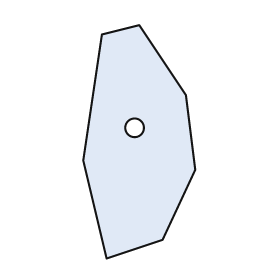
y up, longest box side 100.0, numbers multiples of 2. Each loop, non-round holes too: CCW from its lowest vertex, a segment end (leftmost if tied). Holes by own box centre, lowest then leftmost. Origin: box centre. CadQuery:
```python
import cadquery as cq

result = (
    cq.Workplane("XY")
    .moveTo(-14.0, -50.0)
    .lineTo(10.0, -42.0)
    .lineTo(24.0, -12.0)
    .lineTo(20.0, 20.0)
    .lineTo(0.0, 50.0)
    .lineTo(-16.0, 46.0)
    .lineTo(-24.0, -8.0)
    .close()
    .moveTo(-2.0, 6.0)
    .circle(4.0)
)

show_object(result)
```